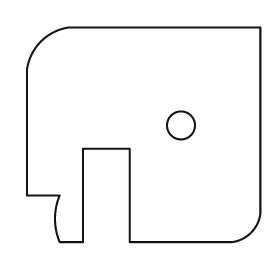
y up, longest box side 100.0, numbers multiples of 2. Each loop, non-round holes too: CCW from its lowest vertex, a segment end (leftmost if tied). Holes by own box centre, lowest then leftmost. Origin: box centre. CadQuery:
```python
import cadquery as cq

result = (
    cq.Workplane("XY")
    .moveTo(-36.0, -46.0)
    .lineTo(-26.0, -46.0)
    .lineTo(-26.0, -6.0)
    .lineTo(-6.0, -6.0)
    .lineTo(-6.0, -46.0)
    .lineTo(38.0, -46.0)
    .threePointArc((46.0, -42.0), (50.0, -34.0))
    .lineTo(50.0, 46.0)
    .lineTo(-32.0, 46.0)
    .threePointArc((-44.0, 40.0), (-50.0, 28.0))
    .lineTo(-50.0, -26.0)
    .lineTo(-36.0, -26.0)
    .threePointArc((-38.0, -36.0), (-36.0, -46.0))
    .close()
    .moveTo(16.0, 4.0)
    .circle(6.0)
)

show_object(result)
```